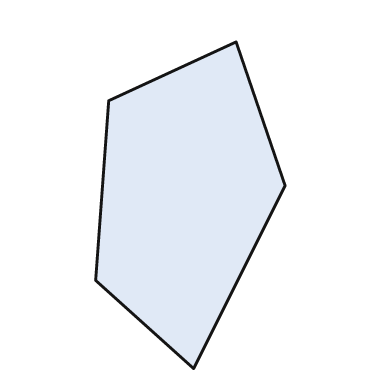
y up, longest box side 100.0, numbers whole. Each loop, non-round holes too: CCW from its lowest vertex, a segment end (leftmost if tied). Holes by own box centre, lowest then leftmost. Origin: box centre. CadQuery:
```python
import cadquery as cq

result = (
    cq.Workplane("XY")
    .moveTo(1.0, -50.0)
    .lineTo(29.0, 6.0)
    .lineTo(14.0, 50.0)
    .lineTo(-25.0, 32.0)
    .lineTo(-29.0, -23.0)
    .close()
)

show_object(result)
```